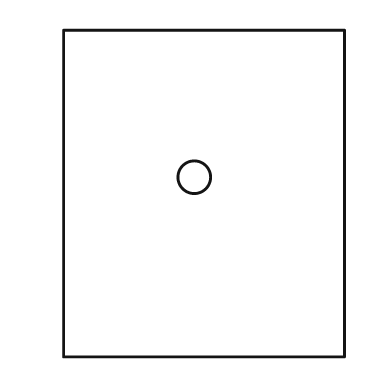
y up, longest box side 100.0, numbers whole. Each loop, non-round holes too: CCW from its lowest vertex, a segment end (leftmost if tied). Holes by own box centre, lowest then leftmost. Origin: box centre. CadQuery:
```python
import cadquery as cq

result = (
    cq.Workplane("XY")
    .moveTo(-43.0, -50.0)
    .lineTo(43.0, -50.0)
    .lineTo(43.0, 50.0)
    .lineTo(-43.0, 50.0)
    .close()
    .moveTo(-3.0, 5.0)
    .circle(5.0)
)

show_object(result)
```